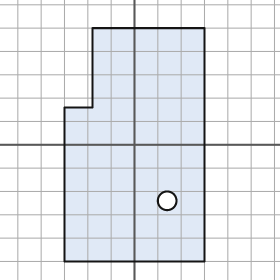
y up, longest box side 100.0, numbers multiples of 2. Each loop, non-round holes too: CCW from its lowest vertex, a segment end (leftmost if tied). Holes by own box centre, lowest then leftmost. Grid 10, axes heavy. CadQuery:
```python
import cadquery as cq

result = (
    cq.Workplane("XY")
    .moveTo(-30.0, -50.0)
    .lineTo(30.0, -50.0)
    .lineTo(30.0, 50.0)
    .lineTo(-18.0, 50.0)
    .lineTo(-18.0, 16.0)
    .lineTo(-30.0, 16.0)
    .close()
    .moveTo(14.0, -24.0)
    .circle(4.0)
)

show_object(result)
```